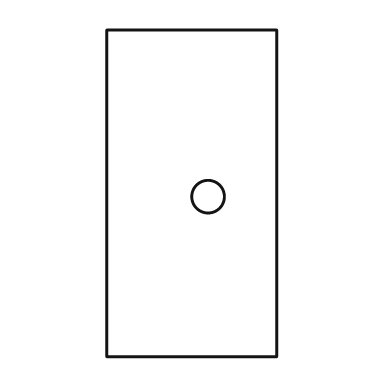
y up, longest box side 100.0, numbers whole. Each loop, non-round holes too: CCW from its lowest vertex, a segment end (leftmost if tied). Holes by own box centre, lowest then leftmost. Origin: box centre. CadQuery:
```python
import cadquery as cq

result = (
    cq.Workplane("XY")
    .moveTo(-26.0, -50.0)
    .lineTo(26.0, -50.0)
    .lineTo(26.0, 50.0)
    .lineTo(-26.0, 50.0)
    .close()
    .moveTo(5.0, -1.0)
    .circle(5.0)
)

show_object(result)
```